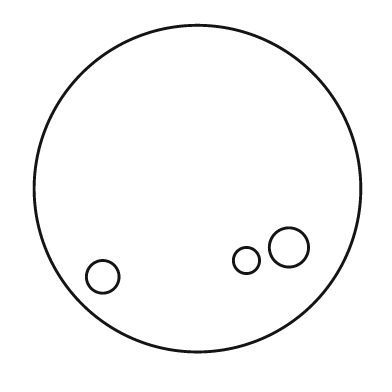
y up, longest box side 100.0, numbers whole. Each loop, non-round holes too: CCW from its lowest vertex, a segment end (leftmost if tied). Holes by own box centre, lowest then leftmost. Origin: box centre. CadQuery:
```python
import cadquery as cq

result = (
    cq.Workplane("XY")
    .moveTo(0.0, 0.0)
    .circle(50.0)
    .moveTo(-29.0, -27.0)
    .circle(5.0)
    .moveTo(15.0, -22.0)
    .circle(4.0)
    .moveTo(28.0, -18.0)
    .circle(6.0)
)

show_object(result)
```